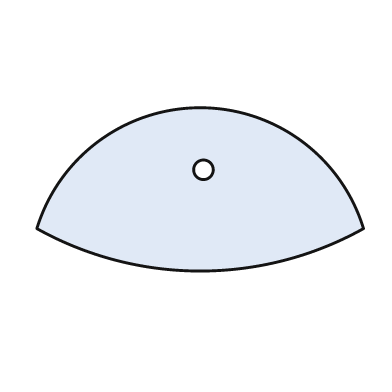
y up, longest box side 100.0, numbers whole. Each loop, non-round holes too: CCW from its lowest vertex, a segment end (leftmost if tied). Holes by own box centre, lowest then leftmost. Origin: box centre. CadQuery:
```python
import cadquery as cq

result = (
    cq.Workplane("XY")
    .moveTo(-50.0, -12.0)
    .threePointArc((0.0, -25.0), (50.0, -12.0))
    .threePointArc((0.0, 25.0), (-50.0, -12.0))
    .close()
    .moveTo(1.0, 6.0)
    .circle(3.0)
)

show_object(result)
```